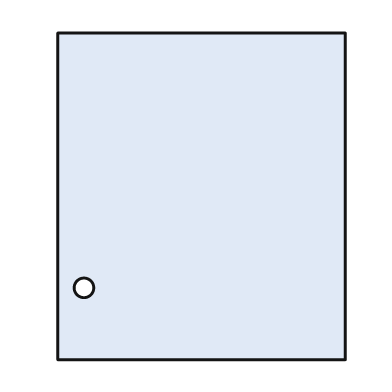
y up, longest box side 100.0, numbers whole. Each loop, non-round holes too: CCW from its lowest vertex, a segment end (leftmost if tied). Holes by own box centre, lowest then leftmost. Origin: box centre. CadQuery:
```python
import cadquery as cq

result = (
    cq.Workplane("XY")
    .moveTo(-44.0, -50.0)
    .lineTo(44.0, -50.0)
    .lineTo(44.0, 50.0)
    .lineTo(-44.0, 50.0)
    .close()
    .moveTo(-36.0, -28.0)
    .circle(3.0)
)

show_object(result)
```